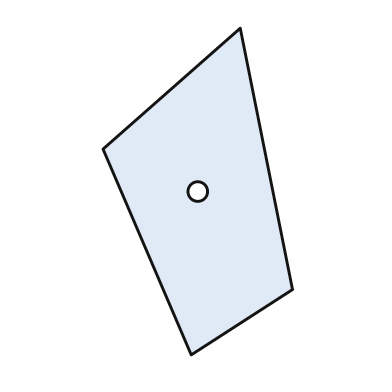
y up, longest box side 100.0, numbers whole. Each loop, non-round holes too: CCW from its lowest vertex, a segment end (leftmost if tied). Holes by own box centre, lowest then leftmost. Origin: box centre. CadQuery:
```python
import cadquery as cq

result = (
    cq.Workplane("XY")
    .moveTo(-2.0, -50.0)
    .lineTo(29.0, -30.0)
    .lineTo(13.0, 50.0)
    .lineTo(-29.0, 13.0)
    .close()
    .moveTo(0.0, 0.0)
    .circle(3.0)
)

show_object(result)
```